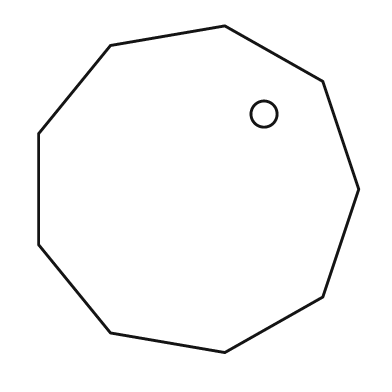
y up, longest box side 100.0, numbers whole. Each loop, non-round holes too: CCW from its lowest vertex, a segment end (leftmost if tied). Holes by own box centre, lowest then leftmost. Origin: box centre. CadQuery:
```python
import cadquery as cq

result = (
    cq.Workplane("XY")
    .moveTo(8.0, -50.0)
    .lineTo(38.0, -33.0)
    .lineTo(49.0, 0.0)
    .lineTo(38.0, 33.0)
    .lineTo(8.0, 50.0)
    .lineTo(-27.0, 44.0)
    .lineTo(-49.0, 17.0)
    .lineTo(-49.0, -17.0)
    .lineTo(-27.0, -44.0)
    .close()
    .moveTo(20.0, 23.0)
    .circle(4.0)
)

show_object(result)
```